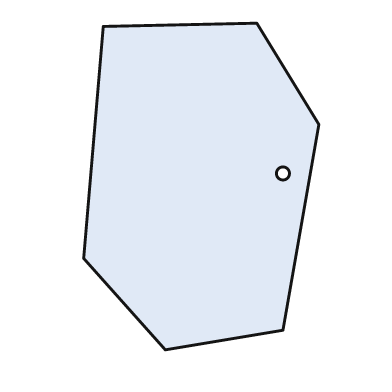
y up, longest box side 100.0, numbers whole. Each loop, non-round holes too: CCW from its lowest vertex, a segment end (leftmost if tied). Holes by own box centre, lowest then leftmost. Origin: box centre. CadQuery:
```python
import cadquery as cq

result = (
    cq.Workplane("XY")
    .moveTo(-11.0, -50.0)
    .lineTo(25.0, -44.0)
    .lineTo(36.0, 19.0)
    .lineTo(17.0, 50.0)
    .lineTo(-30.0, 49.0)
    .lineTo(-36.0, -22.0)
    .close()
    .moveTo(25.0, 4.0)
    .circle(2.0)
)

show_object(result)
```